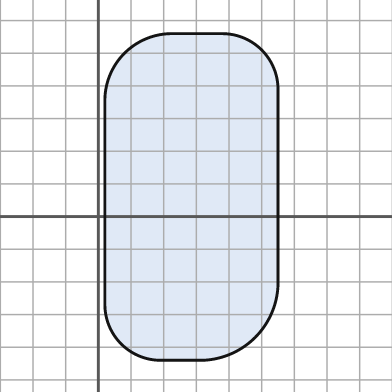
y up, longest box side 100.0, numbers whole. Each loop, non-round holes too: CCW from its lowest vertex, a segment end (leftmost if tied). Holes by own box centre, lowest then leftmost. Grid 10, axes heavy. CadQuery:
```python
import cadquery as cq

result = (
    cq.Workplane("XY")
    .moveTo(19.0, -44.0)
    .lineTo(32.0, -44.0)
    .threePointArc((48.0, -37.0), (55.0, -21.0))
    .lineTo(55.0, 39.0)
    .threePointArc((50.0, 51.0), (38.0, 56.0))
    .lineTo(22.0, 56.0)
    .threePointArc((8.0, 50.0), (2.0, 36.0))
    .lineTo(2.0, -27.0)
    .threePointArc((7.0, -39.0), (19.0, -44.0))
    .close()
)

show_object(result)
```